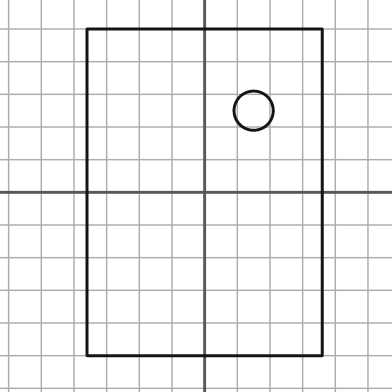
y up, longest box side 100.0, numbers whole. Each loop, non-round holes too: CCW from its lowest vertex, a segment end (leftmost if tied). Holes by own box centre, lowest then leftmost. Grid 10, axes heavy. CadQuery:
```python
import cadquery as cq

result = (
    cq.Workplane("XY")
    .moveTo(-36.0, -50.0)
    .lineTo(36.0, -50.0)
    .lineTo(36.0, 50.0)
    .lineTo(-36.0, 50.0)
    .close()
    .moveTo(15.0, 25.0)
    .circle(6.0)
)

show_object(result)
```